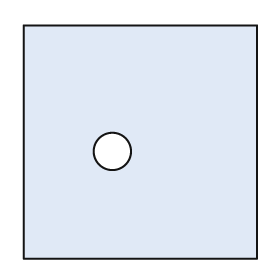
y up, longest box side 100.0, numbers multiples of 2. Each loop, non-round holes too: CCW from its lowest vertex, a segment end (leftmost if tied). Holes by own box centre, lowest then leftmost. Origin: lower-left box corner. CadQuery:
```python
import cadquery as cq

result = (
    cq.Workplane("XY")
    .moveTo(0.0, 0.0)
    .lineTo(100.0, 0.0)
    .lineTo(100.0, 100.0)
    .lineTo(0.0, 100.0)
    .close()
    .moveTo(38.0, 46.0)
    .circle(8.0)
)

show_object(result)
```